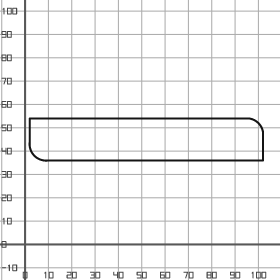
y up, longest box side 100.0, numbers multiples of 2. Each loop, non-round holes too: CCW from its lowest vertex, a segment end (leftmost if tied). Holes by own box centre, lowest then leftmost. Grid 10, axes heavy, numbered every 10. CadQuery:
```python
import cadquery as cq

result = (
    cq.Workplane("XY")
    .moveTo(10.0, 36.0)
    .lineTo(102.0, 36.0)
    .lineTo(102.0, 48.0)
    .threePointArc((100.0, 52.0), (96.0, 54.0))
    .lineTo(2.0, 54.0)
    .lineTo(2.0, 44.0)
    .threePointArc((4.0, 38.0), (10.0, 36.0))
    .close()
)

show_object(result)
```